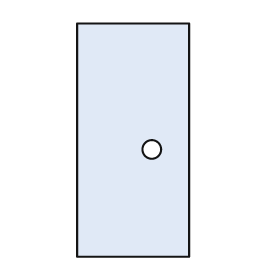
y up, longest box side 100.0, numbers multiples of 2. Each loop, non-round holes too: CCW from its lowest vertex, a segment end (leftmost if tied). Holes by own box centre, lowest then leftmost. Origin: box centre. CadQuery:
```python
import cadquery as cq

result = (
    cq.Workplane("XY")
    .moveTo(-24.0, -50.0)
    .lineTo(24.0, -50.0)
    .lineTo(24.0, 50.0)
    .lineTo(-24.0, 50.0)
    .close()
    .moveTo(8.0, -4.0)
    .circle(4.0)
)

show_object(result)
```